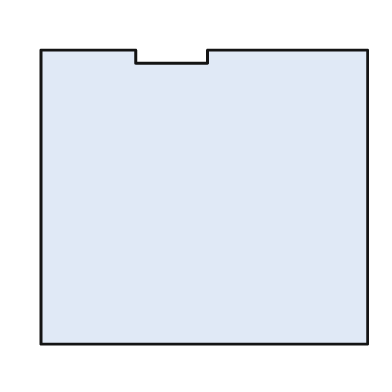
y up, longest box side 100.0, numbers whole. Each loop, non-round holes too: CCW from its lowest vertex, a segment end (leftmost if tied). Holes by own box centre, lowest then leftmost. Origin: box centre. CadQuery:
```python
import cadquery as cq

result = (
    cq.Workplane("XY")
    .moveTo(-50.0, -45.0)
    .lineTo(50.0, -45.0)
    .lineTo(50.0, 45.0)
    .lineTo(1.0, 45.0)
    .lineTo(1.0, 41.0)
    .lineTo(-21.0, 41.0)
    .lineTo(-21.0, 45.0)
    .lineTo(-50.0, 45.0)
    .close()
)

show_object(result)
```